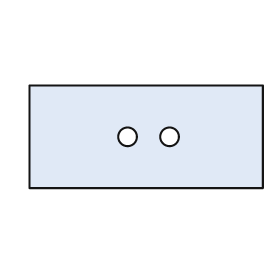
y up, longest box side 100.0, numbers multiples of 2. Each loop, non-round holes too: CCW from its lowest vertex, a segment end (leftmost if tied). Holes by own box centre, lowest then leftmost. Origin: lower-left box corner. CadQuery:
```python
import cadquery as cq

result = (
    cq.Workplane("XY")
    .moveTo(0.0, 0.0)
    .lineTo(100.0, 0.0)
    .lineTo(100.0, 44.0)
    .lineTo(0.0, 44.0)
    .close()
    .moveTo(42.0, 22.0)
    .circle(4.0)
    .moveTo(60.0, 22.0)
    .circle(4.0)
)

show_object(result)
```